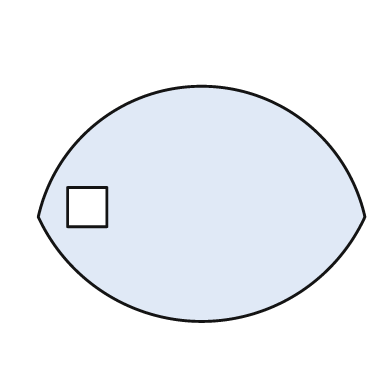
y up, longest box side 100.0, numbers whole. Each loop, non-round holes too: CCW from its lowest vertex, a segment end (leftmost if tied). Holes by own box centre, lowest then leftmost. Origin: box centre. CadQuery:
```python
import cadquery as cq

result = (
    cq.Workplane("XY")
    .moveTo(-50.0, -4.0)
    .threePointArc((0.0, -36.0), (50.0, -4.0))
    .threePointArc((0.0, 36.0), (-50.0, -4.0))
    .close()
    .moveTo(-41.0, -7.0)
    .lineTo(-29.0, -7.0)
    .lineTo(-29.0, 5.0)
    .lineTo(-41.0, 5.0)
    .close()
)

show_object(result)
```